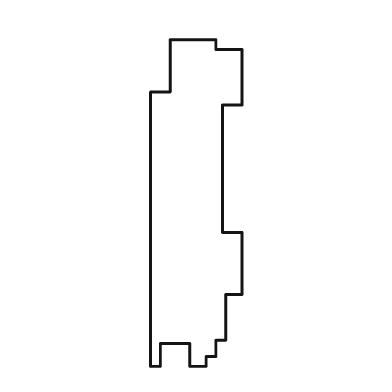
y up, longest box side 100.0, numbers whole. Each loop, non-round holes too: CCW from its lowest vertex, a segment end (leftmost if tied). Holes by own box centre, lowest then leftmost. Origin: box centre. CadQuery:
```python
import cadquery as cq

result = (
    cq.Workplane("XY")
    .moveTo(-14.0, -50.0)
    .lineTo(-11.0, -50.0)
    .lineTo(-11.0, -43.0)
    .lineTo(-2.0, -43.0)
    .lineTo(-2.0, -50.0)
    .lineTo(3.0, -50.0)
    .lineTo(3.0, -47.0)
    .lineTo(6.0, -47.0)
    .lineTo(6.0, -42.0)
    .lineTo(9.0, -42.0)
    .lineTo(9.0, -28.0)
    .lineTo(14.0, -28.0)
    .lineTo(14.0, -9.0)
    .lineTo(8.0, -9.0)
    .lineTo(8.0, 30.0)
    .lineTo(14.0, 30.0)
    .lineTo(14.0, 47.0)
    .lineTo(6.0, 47.0)
    .lineTo(6.0, 50.0)
    .lineTo(-8.0, 50.0)
    .lineTo(-8.0, 34.0)
    .lineTo(-14.0, 34.0)
    .close()
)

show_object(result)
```